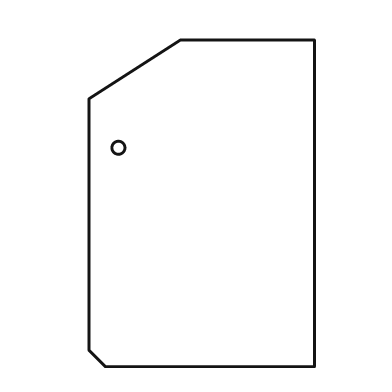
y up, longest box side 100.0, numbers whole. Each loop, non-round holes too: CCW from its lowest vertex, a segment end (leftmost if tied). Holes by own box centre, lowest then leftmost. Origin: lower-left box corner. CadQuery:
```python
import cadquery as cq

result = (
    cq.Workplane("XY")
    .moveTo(5.0, 0.0)
    .lineTo(69.0, 0.0)
    .lineTo(69.0, 100.0)
    .lineTo(28.0, 100.0)
    .lineTo(0.0, 82.0)
    .lineTo(0.0, 5.0)
    .close()
    .moveTo(9.0, 67.0)
    .circle(2.0)
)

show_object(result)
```